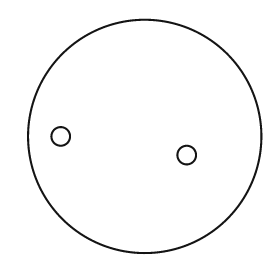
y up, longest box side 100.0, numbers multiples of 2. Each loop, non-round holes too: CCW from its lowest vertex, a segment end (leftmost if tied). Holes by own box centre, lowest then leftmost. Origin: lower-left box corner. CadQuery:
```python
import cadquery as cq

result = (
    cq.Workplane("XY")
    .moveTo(50.0, 50.0)
    .circle(50.0)
    .moveTo(68.0, 42.0)
    .circle(4.0)
    .moveTo(14.0, 50.0)
    .circle(4.0)
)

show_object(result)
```